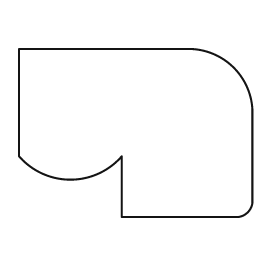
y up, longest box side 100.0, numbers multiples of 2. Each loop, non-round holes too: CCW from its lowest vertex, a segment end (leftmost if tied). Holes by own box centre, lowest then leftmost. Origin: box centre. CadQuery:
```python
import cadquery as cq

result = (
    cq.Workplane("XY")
    .moveTo(-6.0, -36.0)
    .lineTo(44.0, -36.0)
    .threePointArc((48.0, -34.0), (50.0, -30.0))
    .lineTo(50.0, 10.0)
    .threePointArc((42.0, 28.0), (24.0, 36.0))
    .lineTo(-50.0, 36.0)
    .lineTo(-50.0, -10.0)
    .threePointArc((-28.0, -20.0), (-6.0, -10.0))
    .close()
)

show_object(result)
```